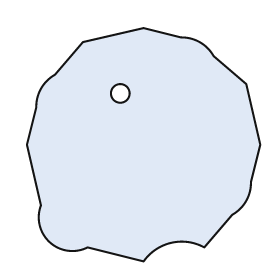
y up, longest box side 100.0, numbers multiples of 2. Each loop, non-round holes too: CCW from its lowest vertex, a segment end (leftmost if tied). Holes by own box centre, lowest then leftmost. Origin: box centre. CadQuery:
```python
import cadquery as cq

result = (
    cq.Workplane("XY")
    .moveTo(0.0, -50.0)
    .threePointArc((12.0, -42.0), (26.0, -44.0))
    .lineTo(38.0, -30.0)
    .threePointArc((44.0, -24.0), (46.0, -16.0))
    .lineTo(50.0, 0.0)
    .lineTo(44.0, 26.0)
    .lineTo(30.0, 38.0)
    .threePointArc((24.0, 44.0), (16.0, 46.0))
    .lineTo(0.0, 50.0)
    .lineTo(-26.0, 44.0)
    .lineTo(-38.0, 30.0)
    .threePointArc((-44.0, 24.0), (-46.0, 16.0))
    .lineTo(-50.0, 0.0)
    .lineTo(-44.0, -26.0)
    .threePointArc((-40.0, -42.0), (-24.0, -44.0))
    .close()
    .moveTo(-10.0, 22.0)
    .circle(4.0)
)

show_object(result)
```